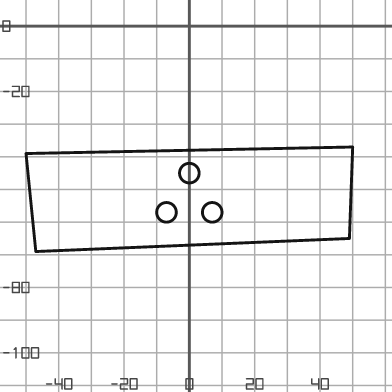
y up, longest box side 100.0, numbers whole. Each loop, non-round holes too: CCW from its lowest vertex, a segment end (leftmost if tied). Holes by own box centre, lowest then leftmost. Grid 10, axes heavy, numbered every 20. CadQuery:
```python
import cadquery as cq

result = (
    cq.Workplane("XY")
    .moveTo(-47.0, -69.0)
    .lineTo(49.0, -65.0)
    .lineTo(50.0, -37.0)
    .lineTo(-50.0, -39.0)
    .close()
    .moveTo(-7.0, -57.0)
    .circle(3.0)
    .moveTo(7.0, -57.0)
    .circle(3.0)
    .moveTo(0.0, -45.0)
    .circle(3.0)
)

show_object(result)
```